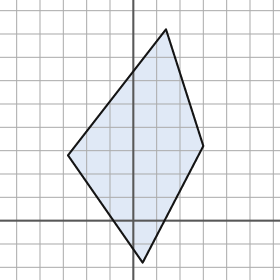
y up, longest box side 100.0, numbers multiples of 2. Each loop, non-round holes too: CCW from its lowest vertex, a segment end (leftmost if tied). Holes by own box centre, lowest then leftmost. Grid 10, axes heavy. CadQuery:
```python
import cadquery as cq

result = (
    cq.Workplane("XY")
    .moveTo(4.0, -18.0)
    .lineTo(30.0, 32.0)
    .lineTo(14.0, 82.0)
    .lineTo(-28.0, 28.0)
    .close()
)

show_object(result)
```